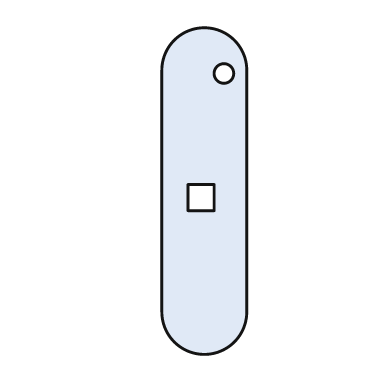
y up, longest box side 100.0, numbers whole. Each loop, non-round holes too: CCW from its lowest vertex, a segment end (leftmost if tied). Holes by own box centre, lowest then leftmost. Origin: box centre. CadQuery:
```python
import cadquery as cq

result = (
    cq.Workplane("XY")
    .moveTo(-13.0, -37.0)
    .threePointArc((0.0, -50.0), (13.0, -37.0))
    .lineTo(13.0, 37.0)
    .threePointArc((0.0, 50.0), (-13.0, 37.0))
    .close()
    .moveTo(-5.0, -6.0)
    .lineTo(3.0, -6.0)
    .lineTo(3.0, 2.0)
    .lineTo(-5.0, 2.0)
    .close()
    .moveTo(6.0, 36.0)
    .circle(3.0)
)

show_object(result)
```